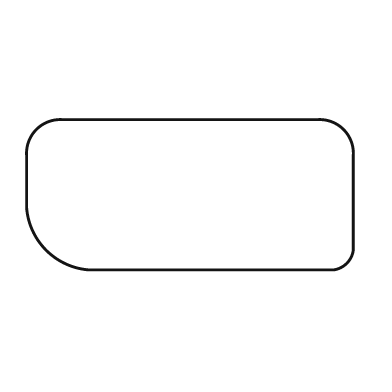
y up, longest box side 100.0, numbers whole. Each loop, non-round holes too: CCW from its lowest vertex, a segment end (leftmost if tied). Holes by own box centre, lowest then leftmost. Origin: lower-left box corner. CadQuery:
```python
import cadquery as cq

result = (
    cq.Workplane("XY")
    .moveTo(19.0, 0.0)
    .lineTo(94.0, 0.0)
    .threePointArc((98.0, 2.0), (100.0, 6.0))
    .lineTo(100.0, 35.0)
    .threePointArc((97.0, 43.0), (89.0, 46.0))
    .lineTo(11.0, 46.0)
    .threePointArc((3.0, 43.0), (0.0, 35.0))
    .lineTo(0.0, 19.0)
    .threePointArc((6.0, 6.0), (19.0, 0.0))
    .close()
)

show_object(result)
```